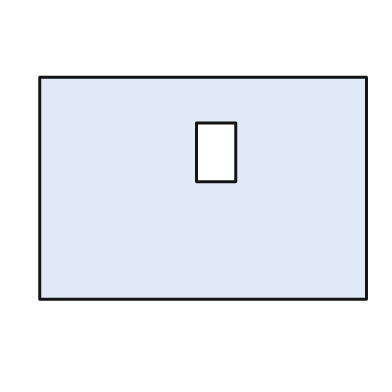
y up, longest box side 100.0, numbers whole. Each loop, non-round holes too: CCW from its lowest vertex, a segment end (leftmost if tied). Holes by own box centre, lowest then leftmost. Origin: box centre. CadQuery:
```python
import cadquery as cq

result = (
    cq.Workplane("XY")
    .moveTo(-50.0, -34.0)
    .lineTo(50.0, -34.0)
    .lineTo(50.0, 34.0)
    .lineTo(-50.0, 34.0)
    .close()
    .moveTo(-2.0, 2.0)
    .lineTo(10.0, 2.0)
    .lineTo(10.0, 20.0)
    .lineTo(-2.0, 20.0)
    .close()
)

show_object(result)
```